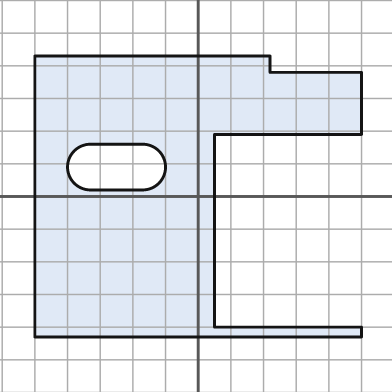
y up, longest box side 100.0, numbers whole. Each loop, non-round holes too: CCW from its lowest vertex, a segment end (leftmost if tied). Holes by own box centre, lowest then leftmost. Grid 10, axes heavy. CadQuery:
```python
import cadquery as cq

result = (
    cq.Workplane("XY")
    .moveTo(-50.0, -43.0)
    .lineTo(50.0, -43.0)
    .lineTo(50.0, -40.0)
    .lineTo(5.0, -40.0)
    .lineTo(5.0, 19.0)
    .lineTo(50.0, 19.0)
    .lineTo(50.0, 38.0)
    .lineTo(22.0, 38.0)
    .lineTo(22.0, 43.0)
    .lineTo(-50.0, 43.0)
    .close()
    .moveTo(-33.0, 2.0)
    .lineTo(-17.0, 2.0)
    .threePointArc((-10.0, 9.0), (-17.0, 16.0))
    .lineTo(-33.0, 16.0)
    .threePointArc((-40.0, 9.0), (-33.0, 2.0))
    .close()
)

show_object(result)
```